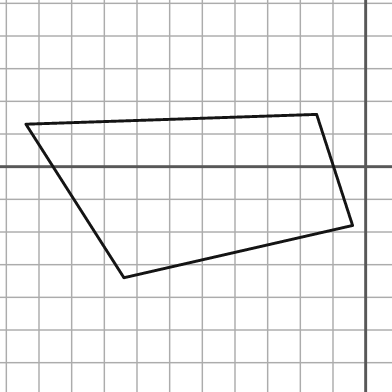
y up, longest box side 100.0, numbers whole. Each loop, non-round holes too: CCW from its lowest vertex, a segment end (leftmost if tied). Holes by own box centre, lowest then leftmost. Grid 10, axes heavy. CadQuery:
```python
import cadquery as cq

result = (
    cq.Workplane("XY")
    .moveTo(-74.0, -34.0)
    .lineTo(-4.0, -18.0)
    .lineTo(-15.0, 16.0)
    .lineTo(-104.0, 13.0)
    .close()
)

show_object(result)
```